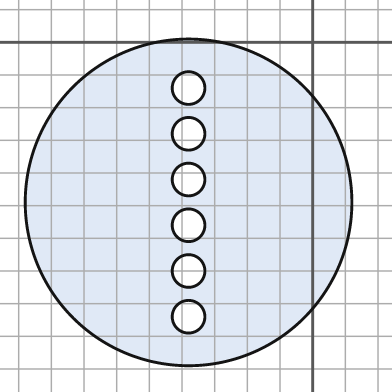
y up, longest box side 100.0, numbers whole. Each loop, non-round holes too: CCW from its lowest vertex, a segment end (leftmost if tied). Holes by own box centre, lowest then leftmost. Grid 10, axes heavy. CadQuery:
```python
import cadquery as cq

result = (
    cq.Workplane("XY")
    .moveTo(-38.0, -49.0)
    .circle(50.0)
    .moveTo(-38.0, -84.0)
    .circle(5.0)
    .moveTo(-38.0, -70.0)
    .circle(5.0)
    .moveTo(-38.0, -56.0)
    .circle(5.0)
    .moveTo(-38.0, -42.0)
    .circle(5.0)
    .moveTo(-38.0, -28.0)
    .circle(5.0)
    .moveTo(-38.0, -14.0)
    .circle(5.0)
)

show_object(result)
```